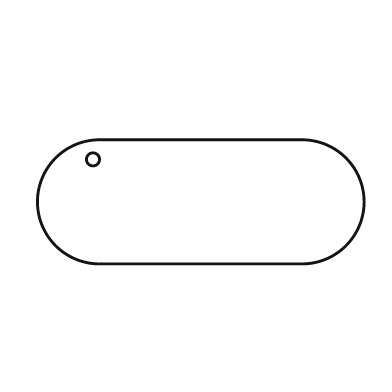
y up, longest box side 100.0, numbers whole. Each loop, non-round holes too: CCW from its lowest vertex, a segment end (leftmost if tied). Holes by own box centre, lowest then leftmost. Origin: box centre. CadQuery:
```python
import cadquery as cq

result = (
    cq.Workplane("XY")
    .moveTo(-31.0, -19.0)
    .lineTo(31.0, -19.0)
    .threePointArc((50.0, 0.0), (31.0, 19.0))
    .lineTo(-31.0, 19.0)
    .threePointArc((-50.0, 0.0), (-31.0, -19.0))
    .close()
    .moveTo(-33.0, 13.0)
    .circle(2.0)
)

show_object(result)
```